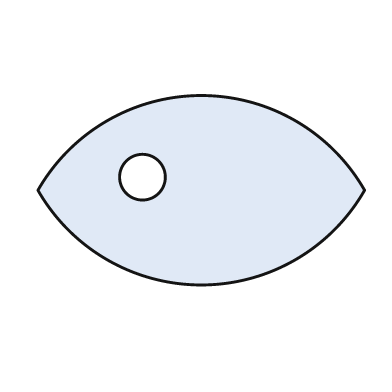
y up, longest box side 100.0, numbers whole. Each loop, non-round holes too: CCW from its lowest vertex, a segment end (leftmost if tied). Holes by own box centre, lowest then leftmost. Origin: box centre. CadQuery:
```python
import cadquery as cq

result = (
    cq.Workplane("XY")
    .moveTo(-50.0, 0.0)
    .threePointArc((0.0, -29.0), (50.0, 0.0))
    .threePointArc((0.0, 29.0), (-50.0, 0.0))
    .close()
    .moveTo(-18.0, 4.0)
    .circle(7.0)
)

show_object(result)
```